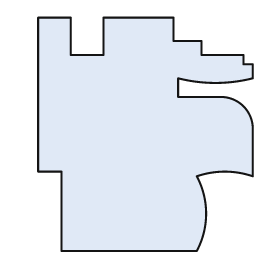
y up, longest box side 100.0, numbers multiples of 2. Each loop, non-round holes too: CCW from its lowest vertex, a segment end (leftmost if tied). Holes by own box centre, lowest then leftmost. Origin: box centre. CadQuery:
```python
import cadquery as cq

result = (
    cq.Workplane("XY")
    .moveTo(-36.0, -50.0)
    .lineTo(22.0, -50.0)
    .threePointArc((26.0, -34.0), (22.0, -18.0))
    .threePointArc((34.0, -16.0), (46.0, -18.0))
    .lineTo(46.0, 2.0)
    .threePointArc((42.0, 12.0), (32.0, 16.0))
    .lineTo(14.0, 16.0)
    .lineTo(14.0, 24.0)
    .threePointArc((30.0, 22.0), (46.0, 24.0))
    .lineTo(46.0, 30.0)
    .lineTo(42.0, 30.0)
    .lineTo(42.0, 34.0)
    .lineTo(24.0, 34.0)
    .lineTo(24.0, 40.0)
    .lineTo(12.0, 40.0)
    .lineTo(12.0, 50.0)
    .lineTo(-18.0, 50.0)
    .lineTo(-18.0, 34.0)
    .lineTo(-32.0, 34.0)
    .lineTo(-32.0, 50.0)
    .lineTo(-46.0, 50.0)
    .lineTo(-46.0, -16.0)
    .lineTo(-36.0, -16.0)
    .close()
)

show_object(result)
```